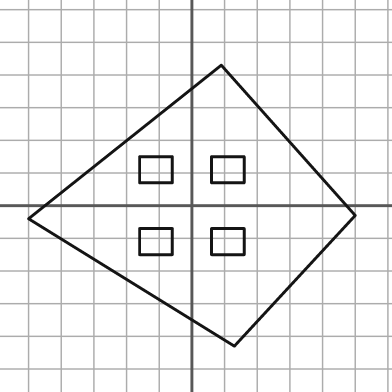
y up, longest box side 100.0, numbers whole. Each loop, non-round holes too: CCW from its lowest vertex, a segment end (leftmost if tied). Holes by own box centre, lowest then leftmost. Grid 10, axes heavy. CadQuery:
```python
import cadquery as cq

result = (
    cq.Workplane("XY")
    .moveTo(13.0, -43.0)
    .lineTo(50.0, -3.0)
    .lineTo(9.0, 43.0)
    .lineTo(-50.0, -4.0)
    .close()
    .moveTo(-16.0, -15.0)
    .lineTo(-6.0, -15.0)
    .lineTo(-6.0, -7.0)
    .lineTo(-16.0, -7.0)
    .close()
    .moveTo(6.0, -15.0)
    .lineTo(16.0, -15.0)
    .lineTo(16.0, -7.0)
    .lineTo(6.0, -7.0)
    .close()
    .moveTo(-16.0, 7.0)
    .lineTo(-6.0, 7.0)
    .lineTo(-6.0, 15.0)
    .lineTo(-16.0, 15.0)
    .close()
    .moveTo(6.0, 7.0)
    .lineTo(16.0, 7.0)
    .lineTo(16.0, 15.0)
    .lineTo(6.0, 15.0)
    .close()
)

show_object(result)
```